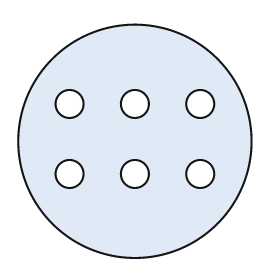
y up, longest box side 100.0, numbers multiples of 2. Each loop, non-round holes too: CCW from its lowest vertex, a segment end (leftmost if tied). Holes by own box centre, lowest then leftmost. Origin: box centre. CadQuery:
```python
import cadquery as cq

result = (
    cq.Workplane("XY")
    .moveTo(0.0, 0.0)
    .circle(50.0)
    .moveTo(-28.0, -14.0)
    .circle(6.0)
    .moveTo(0.0, -14.0)
    .circle(6.0)
    .moveTo(28.0, -14.0)
    .circle(6.0)
    .moveTo(-28.0, 16.0)
    .circle(6.0)
    .moveTo(0.0, 16.0)
    .circle(6.0)
    .moveTo(28.0, 16.0)
    .circle(6.0)
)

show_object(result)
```